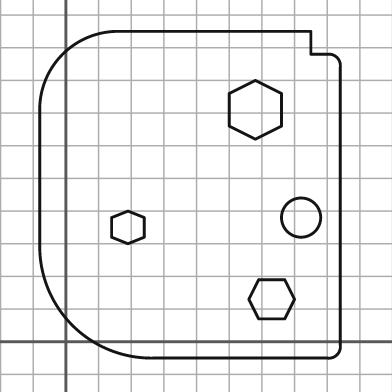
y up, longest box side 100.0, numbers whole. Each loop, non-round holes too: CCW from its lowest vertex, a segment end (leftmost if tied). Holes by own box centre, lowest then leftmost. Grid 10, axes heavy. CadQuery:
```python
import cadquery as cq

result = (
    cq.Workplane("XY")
    .moveTo(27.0, -5.0)
    .lineTo(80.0, -5.0)
    .threePointArc((83.0, -4.0), (84.0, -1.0))
    .lineTo(84.0, 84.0)
    .threePointArc((83.0, 87.0), (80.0, 88.0))
    .lineTo(75.0, 88.0)
    .lineTo(75.0, 95.0)
    .lineTo(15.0, 95.0)
    .threePointArc((-1.0, 88.0), (-8.0, 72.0))
    .lineTo(-8.0, 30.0)
    .threePointArc((2.0, 5.0), (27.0, -5.0))
    .close()
    .moveTo(59.0, 7.0)
    .lineTo(67.0, 7.0)
    .lineTo(70.0, 13.0)
    .lineTo(67.0, 19.0)
    .lineTo(59.0, 19.0)
    .lineTo(56.0, 13.0)
    .close()
    .moveTo(19.0, 30.0)
    .lineTo(24.0, 32.0)
    .lineTo(24.0, 38.0)
    .lineTo(19.0, 40.0)
    .lineTo(14.0, 38.0)
    .lineTo(14.0, 32.0)
    .close()
    .moveTo(72.0, 38.0)
    .circle(6.0)
    .moveTo(58.0, 62.0)
    .lineTo(66.0, 66.0)
    .lineTo(66.0, 76.0)
    .lineTo(58.0, 80.0)
    .lineTo(50.0, 76.0)
    .lineTo(50.0, 66.0)
    .close()
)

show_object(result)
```